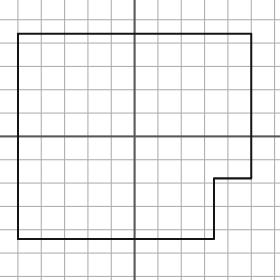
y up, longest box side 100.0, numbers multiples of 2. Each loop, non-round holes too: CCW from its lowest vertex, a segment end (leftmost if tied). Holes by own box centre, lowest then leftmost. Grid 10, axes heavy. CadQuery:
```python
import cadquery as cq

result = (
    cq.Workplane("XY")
    .moveTo(-50.0, -44.0)
    .lineTo(34.0, -44.0)
    .lineTo(34.0, -18.0)
    .lineTo(50.0, -18.0)
    .lineTo(50.0, 44.0)
    .lineTo(-50.0, 44.0)
    .close()
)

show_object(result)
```